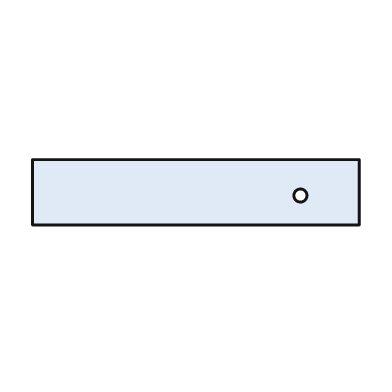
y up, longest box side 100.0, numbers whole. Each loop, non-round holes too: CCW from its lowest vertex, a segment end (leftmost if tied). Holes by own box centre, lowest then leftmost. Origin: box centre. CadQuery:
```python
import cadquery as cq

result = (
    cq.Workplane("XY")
    .moveTo(-50.0, -10.0)
    .lineTo(50.0, -10.0)
    .lineTo(50.0, 10.0)
    .lineTo(-50.0, 10.0)
    .close()
    .moveTo(32.0, -1.0)
    .circle(2.0)
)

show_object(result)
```